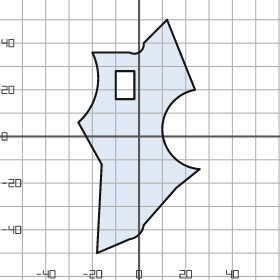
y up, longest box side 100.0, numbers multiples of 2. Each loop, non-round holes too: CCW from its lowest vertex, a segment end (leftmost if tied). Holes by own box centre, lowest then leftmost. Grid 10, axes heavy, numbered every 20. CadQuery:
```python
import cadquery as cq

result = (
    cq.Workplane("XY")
    .moveTo(-18.0, -50.0)
    .lineTo(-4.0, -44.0)
    .threePointArc((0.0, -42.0), (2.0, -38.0))
    .lineTo(16.0, -22.0)
    .lineTo(26.0, -14.0)
    .threePointArc((10.0, 2.0), (24.0, 20.0))
    .lineTo(12.0, 50.0)
    .lineTo(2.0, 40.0)
    .threePointArc((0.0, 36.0), (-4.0, 36.0))
    .lineTo(-20.0, 36.0)
    .threePointArc((-18.0, 20.0), (-26.0, 6.0))
    .lineTo(-16.0, -12.0)
    .close()
    .moveTo(-10.0, 16.0)
    .lineTo(-2.0, 16.0)
    .lineTo(-2.0, 28.0)
    .lineTo(-10.0, 28.0)
    .close()
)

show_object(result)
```